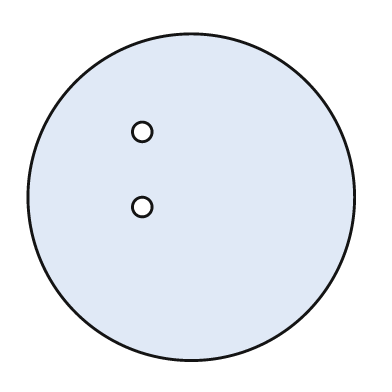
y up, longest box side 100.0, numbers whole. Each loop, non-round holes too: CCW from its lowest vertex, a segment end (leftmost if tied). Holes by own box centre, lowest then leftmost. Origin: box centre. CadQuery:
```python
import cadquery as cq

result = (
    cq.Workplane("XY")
    .moveTo(0.0, 0.0)
    .circle(50.0)
    .moveTo(-15.0, -3.0)
    .circle(3.0)
    .moveTo(-15.0, 20.0)
    .circle(3.0)
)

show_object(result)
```